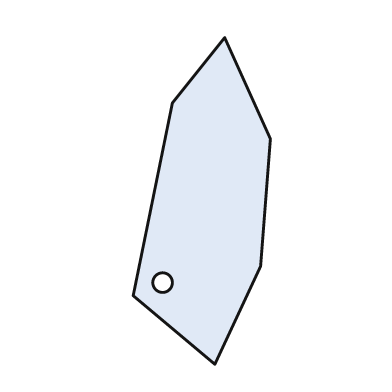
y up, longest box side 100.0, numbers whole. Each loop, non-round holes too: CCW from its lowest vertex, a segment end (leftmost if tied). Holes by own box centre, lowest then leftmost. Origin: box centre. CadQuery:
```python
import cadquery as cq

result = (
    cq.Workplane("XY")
    .moveTo(4.0, -50.0)
    .lineTo(18.0, -20.0)
    .lineTo(21.0, 19.0)
    .lineTo(7.0, 50.0)
    .lineTo(-9.0, 30.0)
    .lineTo(-21.0, -29.0)
    .close()
    .moveTo(-12.0, -25.0)
    .circle(3.0)
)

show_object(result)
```